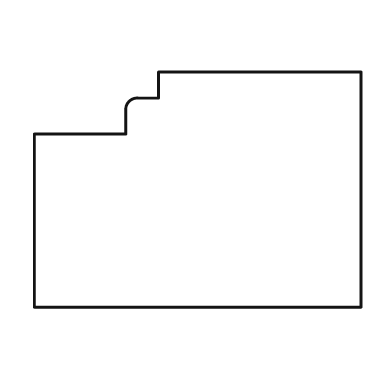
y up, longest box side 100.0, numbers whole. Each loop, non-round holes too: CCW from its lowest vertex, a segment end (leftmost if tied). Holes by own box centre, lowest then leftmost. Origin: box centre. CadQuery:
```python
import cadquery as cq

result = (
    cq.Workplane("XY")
    .moveTo(-50.0, -36.0)
    .lineTo(50.0, -36.0)
    .lineTo(50.0, 36.0)
    .lineTo(-12.0, 36.0)
    .lineTo(-12.0, 28.0)
    .lineTo(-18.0, 28.0)
    .threePointArc((-21.0, 27.0), (-22.0, 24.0))
    .lineTo(-22.0, 17.0)
    .lineTo(-50.0, 17.0)
    .close()
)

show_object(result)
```